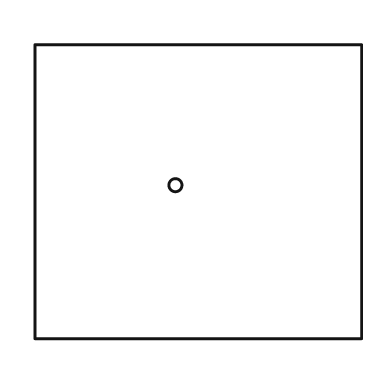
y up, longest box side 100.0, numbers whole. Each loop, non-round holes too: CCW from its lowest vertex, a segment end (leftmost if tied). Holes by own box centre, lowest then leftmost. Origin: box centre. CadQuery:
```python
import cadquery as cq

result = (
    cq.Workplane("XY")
    .moveTo(-50.0, -45.0)
    .lineTo(50.0, -45.0)
    .lineTo(50.0, 45.0)
    .lineTo(-50.0, 45.0)
    .close()
    .moveTo(-7.0, 2.0)
    .circle(2.0)
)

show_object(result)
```